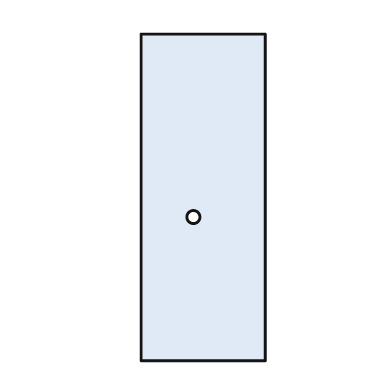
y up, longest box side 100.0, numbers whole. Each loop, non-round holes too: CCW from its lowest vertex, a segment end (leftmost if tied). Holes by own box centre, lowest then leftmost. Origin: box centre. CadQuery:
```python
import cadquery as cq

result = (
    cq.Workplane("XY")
    .moveTo(-19.0, -50.0)
    .lineTo(19.0, -50.0)
    .lineTo(19.0, 50.0)
    .lineTo(-19.0, 50.0)
    .close()
    .moveTo(-3.0, -6.0)
    .circle(2.0)
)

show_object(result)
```